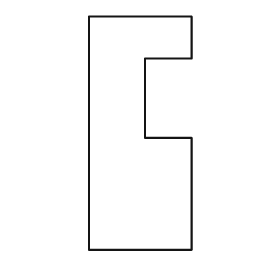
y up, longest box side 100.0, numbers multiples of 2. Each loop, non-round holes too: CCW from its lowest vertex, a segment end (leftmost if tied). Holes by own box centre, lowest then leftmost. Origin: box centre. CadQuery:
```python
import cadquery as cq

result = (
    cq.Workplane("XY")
    .moveTo(-22.0, -50.0)
    .lineTo(22.0, -50.0)
    .lineTo(22.0, -2.0)
    .lineTo(2.0, -2.0)
    .lineTo(2.0, 32.0)
    .lineTo(22.0, 32.0)
    .lineTo(22.0, 50.0)
    .lineTo(-22.0, 50.0)
    .close()
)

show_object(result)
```